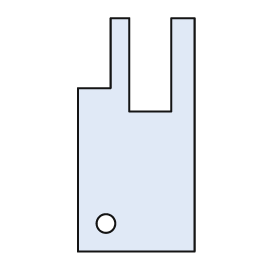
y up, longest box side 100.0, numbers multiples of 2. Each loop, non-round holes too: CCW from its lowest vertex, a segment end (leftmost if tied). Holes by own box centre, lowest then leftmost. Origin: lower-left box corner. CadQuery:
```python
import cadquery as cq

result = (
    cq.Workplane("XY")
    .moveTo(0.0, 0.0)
    .lineTo(50.0, 0.0)
    .lineTo(50.0, 100.0)
    .lineTo(40.0, 100.0)
    .lineTo(40.0, 60.0)
    .lineTo(22.0, 60.0)
    .lineTo(22.0, 100.0)
    .lineTo(14.0, 100.0)
    .lineTo(14.0, 70.0)
    .lineTo(0.0, 70.0)
    .close()
    .moveTo(12.0, 12.0)
    .circle(4.0)
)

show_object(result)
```